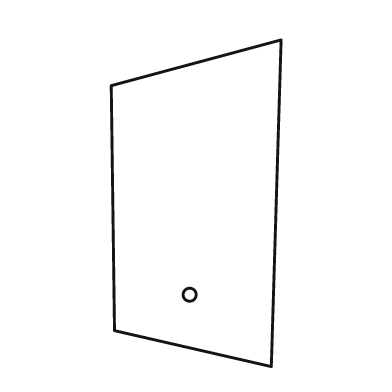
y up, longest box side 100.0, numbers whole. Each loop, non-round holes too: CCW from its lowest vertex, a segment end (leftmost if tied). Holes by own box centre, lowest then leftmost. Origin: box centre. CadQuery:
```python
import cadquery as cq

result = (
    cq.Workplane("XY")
    .moveTo(23.0, -50.0)
    .lineTo(26.0, 50.0)
    .lineTo(-26.0, 36.0)
    .lineTo(-25.0, -39.0)
    .close()
    .moveTo(-2.0, -28.0)
    .circle(2.0)
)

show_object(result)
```